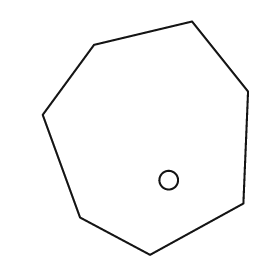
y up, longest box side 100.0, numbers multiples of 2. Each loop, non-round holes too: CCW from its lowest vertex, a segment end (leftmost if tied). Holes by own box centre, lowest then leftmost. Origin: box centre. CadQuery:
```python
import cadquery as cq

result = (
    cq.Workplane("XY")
    .moveTo(2.0, -50.0)
    .lineTo(42.0, -28.0)
    .lineTo(44.0, 20.0)
    .lineTo(20.0, 50.0)
    .lineTo(-22.0, 40.0)
    .lineTo(-44.0, 10.0)
    .lineTo(-28.0, -34.0)
    .close()
    .moveTo(10.0, -18.0)
    .circle(4.0)
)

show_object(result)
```